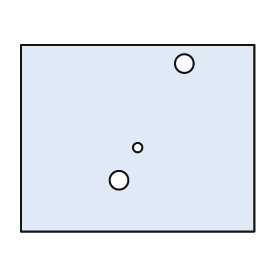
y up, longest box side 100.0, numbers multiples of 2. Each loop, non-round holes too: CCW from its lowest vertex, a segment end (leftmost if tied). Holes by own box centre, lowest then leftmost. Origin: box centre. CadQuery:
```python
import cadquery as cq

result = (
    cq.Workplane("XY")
    .moveTo(-50.0, -40.0)
    .lineTo(50.0, -40.0)
    .lineTo(50.0, 40.0)
    .lineTo(-50.0, 40.0)
    .close()
    .moveTo(-8.0, -18.0)
    .circle(4.0)
    .moveTo(0.0, -4.0)
    .circle(2.0)
    .moveTo(20.0, 32.0)
    .circle(4.0)
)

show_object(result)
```